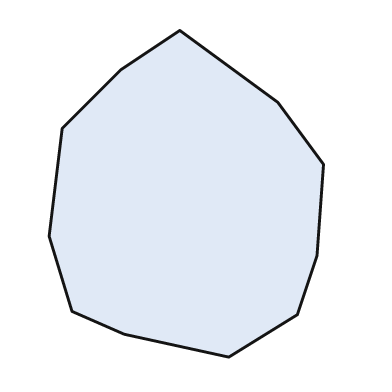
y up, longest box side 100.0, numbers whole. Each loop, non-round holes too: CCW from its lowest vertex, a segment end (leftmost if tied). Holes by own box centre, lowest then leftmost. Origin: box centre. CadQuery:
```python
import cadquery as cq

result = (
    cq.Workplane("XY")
    .moveTo(13.0, -50.0)
    .lineTo(34.0, -37.0)
    .lineTo(40.0, -19.0)
    .lineTo(42.0, 9.0)
    .lineTo(28.0, 28.0)
    .lineTo(-2.0, 50.0)
    .lineTo(-20.0, 38.0)
    .lineTo(-38.0, 20.0)
    .lineTo(-42.0, -13.0)
    .lineTo(-35.0, -36.0)
    .lineTo(-19.0, -43.0)
    .close()
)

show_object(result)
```